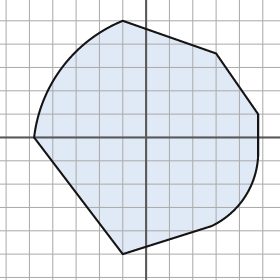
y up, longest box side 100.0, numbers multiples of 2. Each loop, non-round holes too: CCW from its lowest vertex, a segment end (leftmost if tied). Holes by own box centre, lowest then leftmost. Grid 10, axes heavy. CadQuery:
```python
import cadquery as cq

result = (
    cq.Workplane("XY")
    .moveTo(-10.0, -50.0)
    .lineTo(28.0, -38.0)
    .threePointArc((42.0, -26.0), (48.0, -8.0))
    .lineTo(48.0, 10.0)
    .lineTo(30.0, 36.0)
    .lineTo(-10.0, 50.0)
    .threePointArc((-36.0, 30.0), (-48.0, 0.0))
    .close()
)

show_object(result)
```